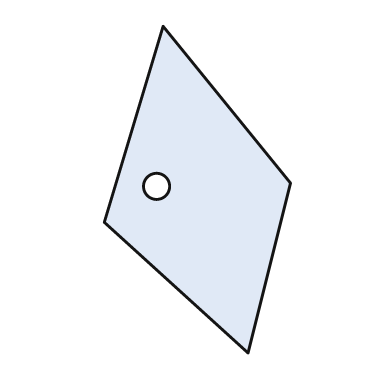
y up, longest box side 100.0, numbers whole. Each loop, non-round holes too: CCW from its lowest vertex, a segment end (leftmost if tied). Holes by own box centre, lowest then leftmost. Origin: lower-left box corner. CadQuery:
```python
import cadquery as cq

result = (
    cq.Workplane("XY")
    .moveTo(44.0, 0.0)
    .lineTo(57.0, 52.0)
    .lineTo(18.0, 100.0)
    .lineTo(0.0, 40.0)
    .close()
    .moveTo(16.0, 51.0)
    .circle(4.0)
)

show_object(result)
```